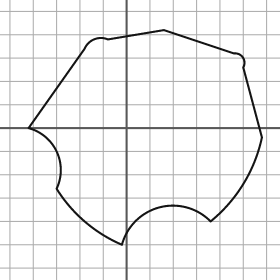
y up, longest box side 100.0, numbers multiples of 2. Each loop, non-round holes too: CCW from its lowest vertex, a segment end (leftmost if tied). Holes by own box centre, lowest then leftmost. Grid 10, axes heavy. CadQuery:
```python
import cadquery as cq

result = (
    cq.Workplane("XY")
    .moveTo(-2.0, -50.0)
    .threePointArc((14.0, -34.0), (36.0, -40.0))
    .threePointArc((50.0, -24.0), (58.0, -4.0))
    .lineTo(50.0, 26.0)
    .threePointArc((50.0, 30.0), (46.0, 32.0))
    .lineTo(16.0, 42.0)
    .lineTo(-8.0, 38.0)
    .threePointArc((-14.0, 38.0), (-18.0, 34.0))
    .lineTo(-42.0, 0.0)
    .threePointArc((-30.0, -10.0), (-30.0, -26.0))
    .threePointArc((-18.0, -40.0), (-2.0, -50.0))
    .close()
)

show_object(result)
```